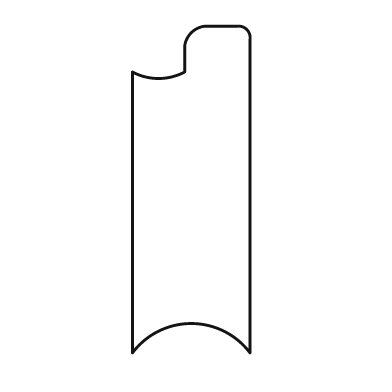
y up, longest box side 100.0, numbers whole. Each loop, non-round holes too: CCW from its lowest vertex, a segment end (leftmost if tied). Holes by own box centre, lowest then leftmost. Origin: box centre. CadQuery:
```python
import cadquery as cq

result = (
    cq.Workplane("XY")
    .moveTo(-18.0, -50.0)
    .threePointArc((0.0, -41.0), (18.0, -50.0))
    .lineTo(18.0, 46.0)
    .threePointArc((17.0, 49.0), (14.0, 50.0))
    .lineTo(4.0, 50.0)
    .threePointArc((0.0, 48.0), (-2.0, 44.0))
    .lineTo(-2.0, 36.0)
    .threePointArc((-10.0, 34.0), (-18.0, 36.0))
    .close()
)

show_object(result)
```